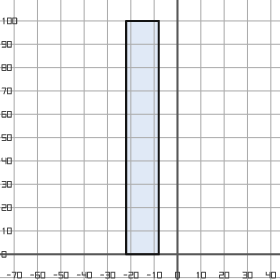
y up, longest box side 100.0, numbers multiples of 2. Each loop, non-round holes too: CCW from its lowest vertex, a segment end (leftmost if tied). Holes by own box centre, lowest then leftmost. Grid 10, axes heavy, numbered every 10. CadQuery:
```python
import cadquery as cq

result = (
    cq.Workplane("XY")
    .moveTo(-22.0, 0.0)
    .lineTo(-8.0, 0.0)
    .lineTo(-8.0, 100.0)
    .lineTo(-22.0, 100.0)
    .close()
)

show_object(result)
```